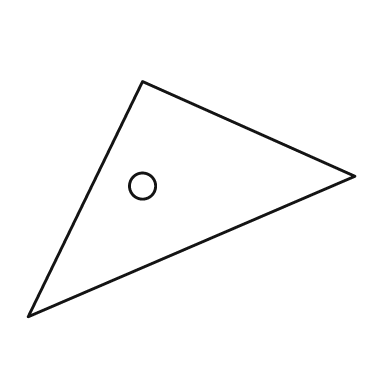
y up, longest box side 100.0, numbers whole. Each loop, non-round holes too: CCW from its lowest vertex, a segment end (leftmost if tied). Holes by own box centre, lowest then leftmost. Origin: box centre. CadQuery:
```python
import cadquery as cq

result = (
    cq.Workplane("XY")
    .moveTo(-50.0, -36.0)
    .lineTo(50.0, 7.0)
    .lineTo(-15.0, 36.0)
    .close()
    .moveTo(-15.0, 4.0)
    .circle(4.0)
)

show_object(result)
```